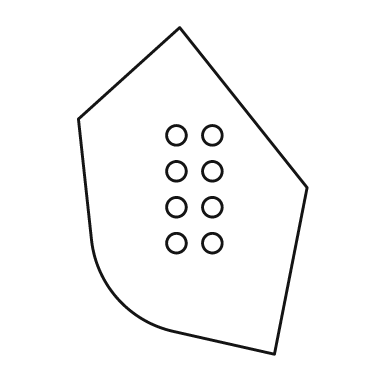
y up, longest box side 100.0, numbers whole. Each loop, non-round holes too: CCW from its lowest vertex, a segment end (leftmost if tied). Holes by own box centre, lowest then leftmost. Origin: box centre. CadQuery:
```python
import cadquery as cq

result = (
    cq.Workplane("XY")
    .moveTo(25.0, -50.0)
    .lineTo(35.0, 1.0)
    .lineTo(-4.0, 50.0)
    .lineTo(-35.0, 22.0)
    .lineTo(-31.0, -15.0)
    .threePointArc((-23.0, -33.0), (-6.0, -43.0))
    .close()
    .moveTo(-5.0, -16.0)
    .circle(3.0)
    .moveTo(6.0, -16.0)
    .circle(3.0)
    .moveTo(-5.0, -5.0)
    .circle(3.0)
    .moveTo(6.0, -5.0)
    .circle(3.0)
    .moveTo(-5.0, 6.0)
    .circle(3.0)
    .moveTo(6.0, 6.0)
    .circle(3.0)
    .moveTo(-5.0, 17.0)
    .circle(3.0)
    .moveTo(6.0, 17.0)
    .circle(3.0)
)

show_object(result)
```